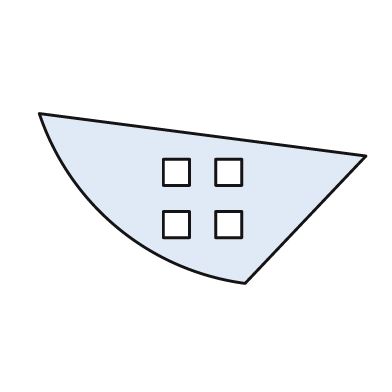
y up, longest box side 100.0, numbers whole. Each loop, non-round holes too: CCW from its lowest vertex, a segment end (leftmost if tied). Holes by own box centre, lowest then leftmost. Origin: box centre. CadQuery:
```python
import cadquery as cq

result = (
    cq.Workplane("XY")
    .moveTo(13.0, -26.0)
    .lineTo(50.0, 13.0)
    .lineTo(-50.0, 26.0)
    .threePointArc((-26.0, -9.0), (13.0, -26.0))
    .close()
    .moveTo(-12.0, -12.0)
    .lineTo(-4.0, -12.0)
    .lineTo(-4.0, -4.0)
    .lineTo(-12.0, -4.0)
    .close()
    .moveTo(4.0, -12.0)
    .lineTo(12.0, -12.0)
    .lineTo(12.0, -4.0)
    .lineTo(4.0, -4.0)
    .close()
    .moveTo(-12.0, 4.0)
    .lineTo(-4.0, 4.0)
    .lineTo(-4.0, 12.0)
    .lineTo(-12.0, 12.0)
    .close()
    .moveTo(4.0, 4.0)
    .lineTo(12.0, 4.0)
    .lineTo(12.0, 12.0)
    .lineTo(4.0, 12.0)
    .close()
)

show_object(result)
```